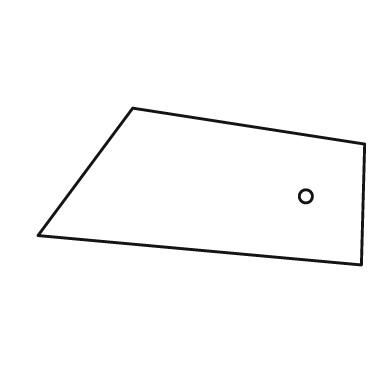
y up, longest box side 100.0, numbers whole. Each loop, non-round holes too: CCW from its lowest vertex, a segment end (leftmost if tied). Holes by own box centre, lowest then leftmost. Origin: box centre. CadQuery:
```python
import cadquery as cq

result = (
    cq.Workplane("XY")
    .moveTo(49.0, -24.0)
    .lineTo(50.0, 13.0)
    .lineTo(-21.0, 24.0)
    .lineTo(-50.0, -15.0)
    .close()
    .moveTo(32.0, -3.0)
    .circle(2.0)
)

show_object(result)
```